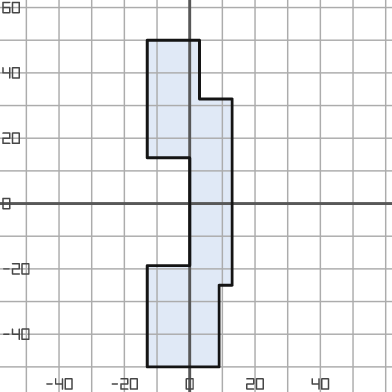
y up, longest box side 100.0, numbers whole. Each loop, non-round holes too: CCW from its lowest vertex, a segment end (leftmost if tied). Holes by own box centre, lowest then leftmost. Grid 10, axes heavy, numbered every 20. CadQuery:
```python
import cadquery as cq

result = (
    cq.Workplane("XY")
    .moveTo(-13.0, -50.0)
    .lineTo(9.0, -50.0)
    .lineTo(9.0, -25.0)
    .lineTo(13.0, -25.0)
    .lineTo(13.0, 32.0)
    .lineTo(3.0, 32.0)
    .lineTo(3.0, 50.0)
    .lineTo(-13.0, 50.0)
    .lineTo(-13.0, 14.0)
    .lineTo(0.0, 14.0)
    .lineTo(0.0, -19.0)
    .lineTo(-13.0, -19.0)
    .close()
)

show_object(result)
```